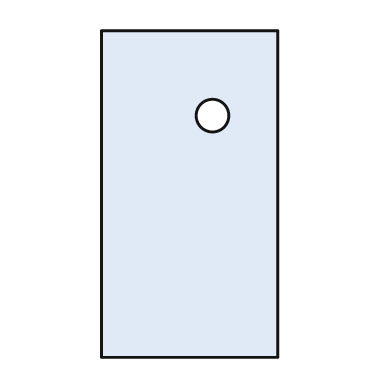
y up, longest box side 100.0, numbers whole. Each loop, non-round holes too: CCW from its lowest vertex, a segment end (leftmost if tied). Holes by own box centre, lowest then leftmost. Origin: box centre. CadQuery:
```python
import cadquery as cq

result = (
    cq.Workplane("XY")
    .moveTo(-27.0, -50.0)
    .lineTo(27.0, -50.0)
    .lineTo(27.0, 50.0)
    .lineTo(-27.0, 50.0)
    .close()
    .moveTo(7.0, 24.0)
    .circle(5.0)
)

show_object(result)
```